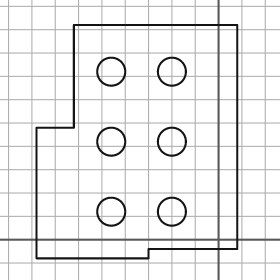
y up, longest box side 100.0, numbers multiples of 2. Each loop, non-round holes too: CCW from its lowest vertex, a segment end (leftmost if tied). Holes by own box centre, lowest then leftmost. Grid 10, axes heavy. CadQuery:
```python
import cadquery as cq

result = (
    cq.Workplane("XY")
    .moveTo(-78.0, -8.0)
    .lineTo(-30.0, -8.0)
    .lineTo(-30.0, -4.0)
    .lineTo(8.0, -4.0)
    .lineTo(8.0, 92.0)
    .lineTo(-62.0, 92.0)
    .lineTo(-62.0, 48.0)
    .lineTo(-78.0, 48.0)
    .close()
    .moveTo(-46.0, 12.0)
    .circle(6.0)
    .moveTo(-20.0, 12.0)
    .circle(6.0)
    .moveTo(-46.0, 42.0)
    .circle(6.0)
    .moveTo(-20.0, 42.0)
    .circle(6.0)
    .moveTo(-46.0, 72.0)
    .circle(6.0)
    .moveTo(-20.0, 72.0)
    .circle(6.0)
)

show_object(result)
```